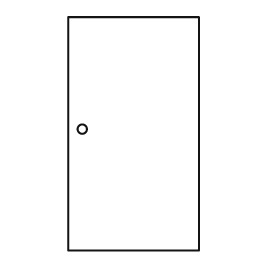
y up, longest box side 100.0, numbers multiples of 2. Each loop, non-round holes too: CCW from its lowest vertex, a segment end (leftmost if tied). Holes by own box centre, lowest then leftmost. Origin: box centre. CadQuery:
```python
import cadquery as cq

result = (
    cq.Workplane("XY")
    .moveTo(-28.0, -50.0)
    .lineTo(28.0, -50.0)
    .lineTo(28.0, 50.0)
    .lineTo(-28.0, 50.0)
    .close()
    .moveTo(-22.0, 2.0)
    .circle(2.0)
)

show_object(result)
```